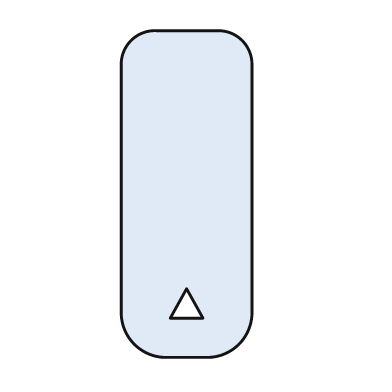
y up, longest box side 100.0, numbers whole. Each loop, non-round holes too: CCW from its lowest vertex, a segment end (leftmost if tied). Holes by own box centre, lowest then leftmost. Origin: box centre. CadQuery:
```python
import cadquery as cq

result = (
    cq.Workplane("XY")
    .moveTo(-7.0, -50.0)
    .lineTo(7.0, -50.0)
    .threePointArc((16.0, -46.0), (20.0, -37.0))
    .lineTo(20.0, 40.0)
    .threePointArc((17.0, 47.0), (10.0, 50.0))
    .lineTo(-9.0, 50.0)
    .threePointArc((-17.0, 47.0), (-20.0, 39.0))
    .lineTo(-20.0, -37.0)
    .threePointArc((-16.0, -46.0), (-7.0, -50.0))
    .close()
    .moveTo(-5.0, -38.0)
    .lineTo(5.0, -38.0)
    .lineTo(0.0, -29.0)
    .close()
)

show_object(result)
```